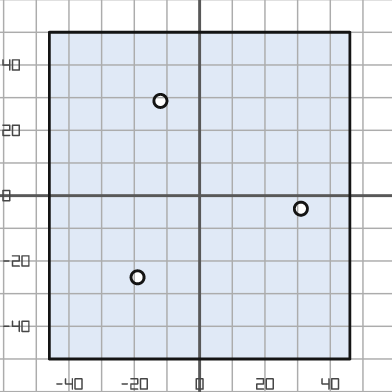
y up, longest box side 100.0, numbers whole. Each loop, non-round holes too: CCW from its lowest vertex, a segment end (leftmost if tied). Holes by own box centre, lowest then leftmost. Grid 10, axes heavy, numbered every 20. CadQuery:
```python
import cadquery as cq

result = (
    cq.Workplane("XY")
    .moveTo(-46.0, -50.0)
    .lineTo(46.0, -50.0)
    .lineTo(46.0, 50.0)
    .lineTo(-46.0, 50.0)
    .close()
    .moveTo(-19.0, -25.0)
    .circle(2.0)
    .moveTo(31.0, -4.0)
    .circle(2.0)
    .moveTo(-12.0, 29.0)
    .circle(2.0)
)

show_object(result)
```